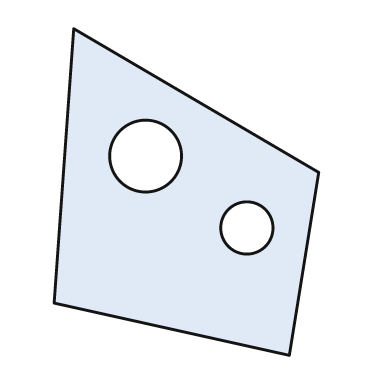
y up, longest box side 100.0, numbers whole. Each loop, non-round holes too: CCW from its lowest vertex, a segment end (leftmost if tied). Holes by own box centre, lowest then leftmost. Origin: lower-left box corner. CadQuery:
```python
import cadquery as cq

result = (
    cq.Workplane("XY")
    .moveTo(72.0, 0.0)
    .lineTo(81.0, 56.0)
    .lineTo(6.0, 100.0)
    .lineTo(0.0, 16.0)
    .close()
    .moveTo(59.0, 39.0)
    .circle(8.0)
    .moveTo(28.0, 61.0)
    .circle(11.0)
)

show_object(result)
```